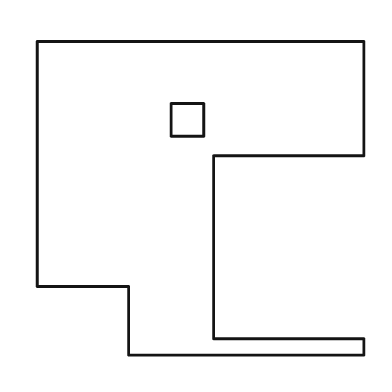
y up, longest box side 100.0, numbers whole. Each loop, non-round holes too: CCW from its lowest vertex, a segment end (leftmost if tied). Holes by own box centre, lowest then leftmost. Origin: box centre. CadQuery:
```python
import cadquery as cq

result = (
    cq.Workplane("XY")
    .moveTo(-22.0, -48.0)
    .lineTo(50.0, -48.0)
    .lineTo(50.0, -43.0)
    .lineTo(4.0, -43.0)
    .lineTo(4.0, 13.0)
    .lineTo(50.0, 13.0)
    .lineTo(50.0, 48.0)
    .lineTo(-50.0, 48.0)
    .lineTo(-50.0, -27.0)
    .lineTo(-22.0, -27.0)
    .close()
    .moveTo(-9.0, 19.0)
    .lineTo(1.0, 19.0)
    .lineTo(1.0, 29.0)
    .lineTo(-9.0, 29.0)
    .close()
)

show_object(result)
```